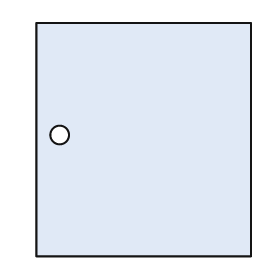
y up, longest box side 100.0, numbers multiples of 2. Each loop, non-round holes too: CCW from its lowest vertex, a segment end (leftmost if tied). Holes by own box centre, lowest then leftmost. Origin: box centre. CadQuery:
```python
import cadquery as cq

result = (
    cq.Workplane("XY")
    .moveTo(-46.0, -50.0)
    .lineTo(46.0, -50.0)
    .lineTo(46.0, 50.0)
    .lineTo(-46.0, 50.0)
    .close()
    .moveTo(-36.0, 2.0)
    .circle(4.0)
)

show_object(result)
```